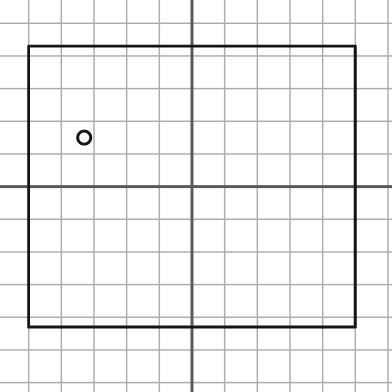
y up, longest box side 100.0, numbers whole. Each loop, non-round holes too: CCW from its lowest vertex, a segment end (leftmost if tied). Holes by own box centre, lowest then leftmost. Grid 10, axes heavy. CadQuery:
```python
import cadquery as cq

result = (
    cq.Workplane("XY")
    .moveTo(-50.0, -43.0)
    .lineTo(50.0, -43.0)
    .lineTo(50.0, 43.0)
    .lineTo(-50.0, 43.0)
    .close()
    .moveTo(-33.0, 15.0)
    .circle(2.0)
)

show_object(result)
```